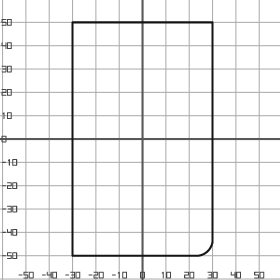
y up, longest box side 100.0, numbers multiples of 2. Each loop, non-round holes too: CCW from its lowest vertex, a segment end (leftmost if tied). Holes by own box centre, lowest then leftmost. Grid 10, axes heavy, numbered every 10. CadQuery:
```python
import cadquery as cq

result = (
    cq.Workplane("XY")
    .moveTo(-30.0, -50.0)
    .lineTo(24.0, -50.0)
    .threePointArc((28.0, -48.0), (30.0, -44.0))
    .lineTo(30.0, 50.0)
    .lineTo(-30.0, 50.0)
    .close()
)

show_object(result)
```